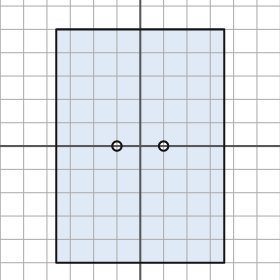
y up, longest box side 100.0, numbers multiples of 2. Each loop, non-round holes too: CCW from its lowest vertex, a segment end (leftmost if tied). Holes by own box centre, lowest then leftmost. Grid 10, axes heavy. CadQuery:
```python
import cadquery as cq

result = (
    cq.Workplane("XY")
    .moveTo(-36.0, -50.0)
    .lineTo(36.0, -50.0)
    .lineTo(36.0, 50.0)
    .lineTo(-36.0, 50.0)
    .close()
    .moveTo(-10.0, 0.0)
    .circle(2.0)
    .moveTo(10.0, 0.0)
    .circle(2.0)
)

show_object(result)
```